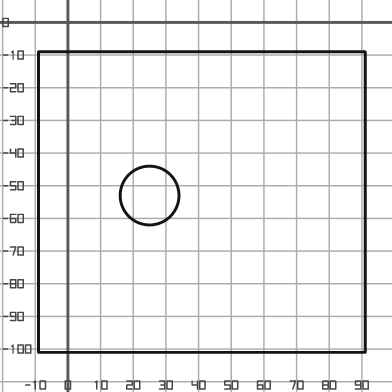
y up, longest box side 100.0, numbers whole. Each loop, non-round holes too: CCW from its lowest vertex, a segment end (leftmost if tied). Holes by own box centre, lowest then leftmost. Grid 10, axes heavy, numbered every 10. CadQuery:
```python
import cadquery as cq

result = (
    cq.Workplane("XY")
    .moveTo(-9.0, -101.0)
    .lineTo(91.0, -101.0)
    .lineTo(91.0, -9.0)
    .lineTo(-9.0, -9.0)
    .close()
    .moveTo(25.0, -53.0)
    .circle(9.0)
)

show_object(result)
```